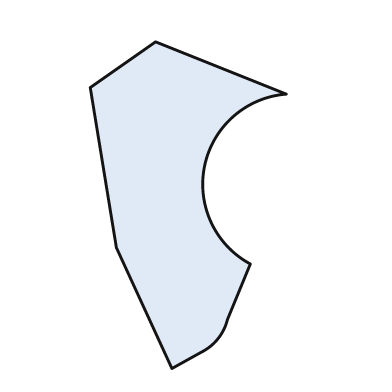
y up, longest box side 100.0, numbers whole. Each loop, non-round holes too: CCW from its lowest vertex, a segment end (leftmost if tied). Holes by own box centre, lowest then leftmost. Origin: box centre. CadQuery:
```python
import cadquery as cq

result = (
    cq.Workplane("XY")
    .moveTo(-5.0, -50.0)
    .lineTo(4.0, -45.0)
    .threePointArc((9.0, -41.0), (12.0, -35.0))
    .lineTo(19.0, -18.0)
    .threePointArc((5.0, 12.0), (30.0, 34.0))
    .lineTo(-10.0, 50.0)
    .lineTo(-30.0, 36.0)
    .lineTo(-22.0, -13.0)
    .close()
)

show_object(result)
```